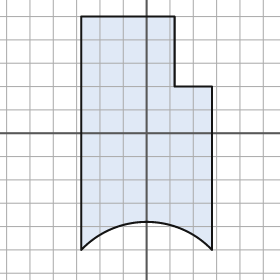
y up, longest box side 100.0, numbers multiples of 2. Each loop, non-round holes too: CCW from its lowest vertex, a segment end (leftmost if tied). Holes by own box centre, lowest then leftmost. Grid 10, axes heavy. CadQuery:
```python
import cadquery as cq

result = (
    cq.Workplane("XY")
    .moveTo(-28.0, -50.0)
    .threePointArc((0.0, -38.0), (28.0, -50.0))
    .lineTo(28.0, 20.0)
    .lineTo(12.0, 20.0)
    .lineTo(12.0, 50.0)
    .lineTo(-28.0, 50.0)
    .close()
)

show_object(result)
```